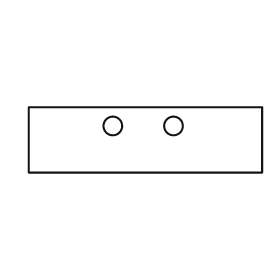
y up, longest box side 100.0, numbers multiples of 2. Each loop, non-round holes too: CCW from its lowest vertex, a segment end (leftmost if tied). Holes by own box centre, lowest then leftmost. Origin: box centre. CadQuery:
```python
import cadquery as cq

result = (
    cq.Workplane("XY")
    .moveTo(-50.0, -14.0)
    .lineTo(50.0, -14.0)
    .lineTo(50.0, 14.0)
    .lineTo(-50.0, 14.0)
    .close()
    .moveTo(-14.0, 6.0)
    .circle(4.0)
    .moveTo(12.0, 6.0)
    .circle(4.0)
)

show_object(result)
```